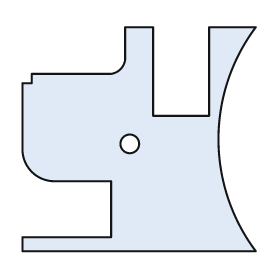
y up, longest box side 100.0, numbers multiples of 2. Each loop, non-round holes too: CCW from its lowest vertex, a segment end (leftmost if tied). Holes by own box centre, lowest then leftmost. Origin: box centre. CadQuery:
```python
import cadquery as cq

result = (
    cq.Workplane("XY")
    .moveTo(-50.0, -48.0)
    .lineTo(50.0, -48.0)
    .threePointArc((34.0, 0.0), (50.0, 48.0))
    .lineTo(30.0, 48.0)
    .lineTo(30.0, 10.0)
    .lineTo(6.0, 10.0)
    .lineTo(6.0, 48.0)
    .lineTo(-6.0, 48.0)
    .lineTo(-6.0, 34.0)
    .threePointArc((-8.0, 30.0), (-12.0, 28.0))
    .lineTo(-46.0, 28.0)
    .lineTo(-46.0, 24.0)
    .lineTo(-50.0, 24.0)
    .lineTo(-50.0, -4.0)
    .threePointArc((-46.0, -14.0), (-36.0, -18.0))
    .lineTo(-12.0, -18.0)
    .lineTo(-12.0, -42.0)
    .lineTo(-50.0, -42.0)
    .close()
    .moveTo(-4.0, -2.0)
    .circle(4.0)
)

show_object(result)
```